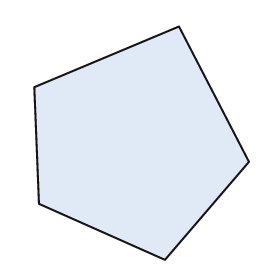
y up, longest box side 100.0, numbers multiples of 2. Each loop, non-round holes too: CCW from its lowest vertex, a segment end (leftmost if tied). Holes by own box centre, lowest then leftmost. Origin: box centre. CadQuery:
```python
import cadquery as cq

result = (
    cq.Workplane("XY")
    .moveTo(10.0, -50.0)
    .lineTo(46.0, -8.0)
    .lineTo(16.0, 50.0)
    .lineTo(-46.0, 24.0)
    .lineTo(-44.0, -26.0)
    .close()
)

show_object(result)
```